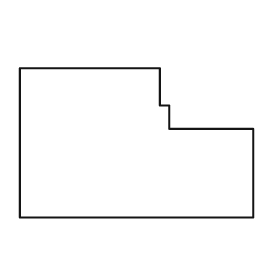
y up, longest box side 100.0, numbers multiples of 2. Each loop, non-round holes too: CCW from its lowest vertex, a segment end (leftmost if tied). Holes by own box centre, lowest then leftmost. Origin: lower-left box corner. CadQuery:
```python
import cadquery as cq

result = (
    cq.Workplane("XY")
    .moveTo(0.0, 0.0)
    .lineTo(100.0, 0.0)
    .lineTo(100.0, 38.0)
    .lineTo(64.0, 38.0)
    .lineTo(64.0, 48.0)
    .lineTo(60.0, 48.0)
    .lineTo(60.0, 64.0)
    .lineTo(0.0, 64.0)
    .close()
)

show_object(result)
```